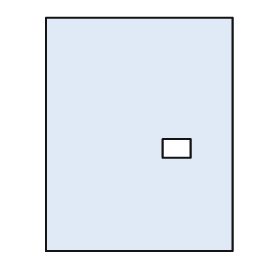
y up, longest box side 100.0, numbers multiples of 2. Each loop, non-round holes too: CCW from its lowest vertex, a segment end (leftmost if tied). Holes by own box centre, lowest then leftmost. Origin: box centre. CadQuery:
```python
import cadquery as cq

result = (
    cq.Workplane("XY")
    .moveTo(-40.0, -50.0)
    .lineTo(40.0, -50.0)
    .lineTo(40.0, 50.0)
    .lineTo(-40.0, 50.0)
    .close()
    .moveTo(10.0, -10.0)
    .lineTo(22.0, -10.0)
    .lineTo(22.0, -2.0)
    .lineTo(10.0, -2.0)
    .close()
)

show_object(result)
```